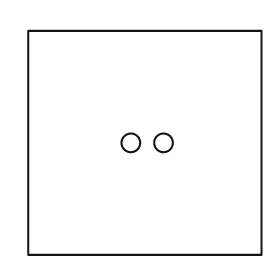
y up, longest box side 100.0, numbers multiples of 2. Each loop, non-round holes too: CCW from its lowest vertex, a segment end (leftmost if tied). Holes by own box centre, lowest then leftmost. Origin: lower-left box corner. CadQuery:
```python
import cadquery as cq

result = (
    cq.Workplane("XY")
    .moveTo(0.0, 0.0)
    .lineTo(100.0, 0.0)
    .lineTo(100.0, 96.0)
    .lineTo(0.0, 96.0)
    .close()
    .moveTo(44.0, 48.0)
    .circle(4.0)
    .moveTo(58.0, 48.0)
    .circle(4.0)
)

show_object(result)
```